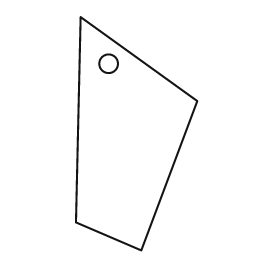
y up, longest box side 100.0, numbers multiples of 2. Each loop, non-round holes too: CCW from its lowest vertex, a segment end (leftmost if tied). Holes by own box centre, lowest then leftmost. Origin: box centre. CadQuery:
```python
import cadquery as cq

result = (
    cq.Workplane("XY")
    .moveTo(2.0, -50.0)
    .lineTo(26.0, 14.0)
    .lineTo(-24.0, 50.0)
    .lineTo(-26.0, -38.0)
    .close()
    .moveTo(-12.0, 30.0)
    .circle(4.0)
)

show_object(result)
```